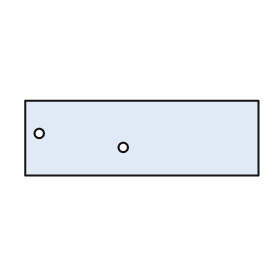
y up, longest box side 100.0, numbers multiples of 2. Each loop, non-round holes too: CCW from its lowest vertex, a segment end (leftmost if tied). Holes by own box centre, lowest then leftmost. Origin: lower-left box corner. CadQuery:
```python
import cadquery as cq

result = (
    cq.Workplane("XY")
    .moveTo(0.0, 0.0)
    .lineTo(100.0, 0.0)
    .lineTo(100.0, 32.0)
    .lineTo(0.0, 32.0)
    .close()
    .moveTo(42.0, 12.0)
    .circle(2.0)
    .moveTo(6.0, 18.0)
    .circle(2.0)
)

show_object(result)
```